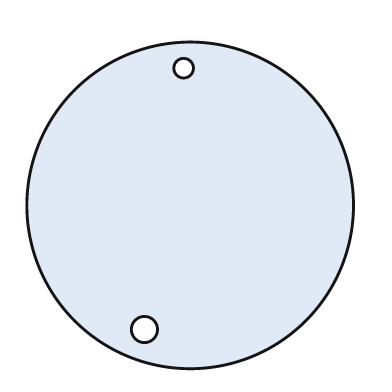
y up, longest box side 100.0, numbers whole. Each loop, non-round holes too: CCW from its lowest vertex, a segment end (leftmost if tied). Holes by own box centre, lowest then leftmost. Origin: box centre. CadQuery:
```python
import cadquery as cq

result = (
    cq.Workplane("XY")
    .moveTo(0.0, 0.0)
    .circle(50.0)
    .moveTo(-14.0, -38.0)
    .circle(4.0)
    .moveTo(-2.0, 42.0)
    .circle(3.0)
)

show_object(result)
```